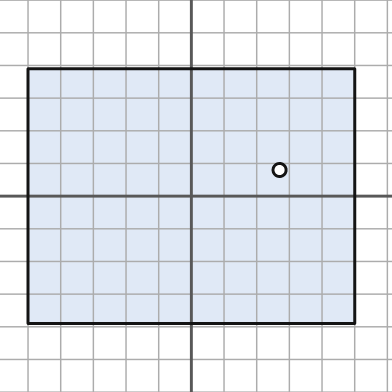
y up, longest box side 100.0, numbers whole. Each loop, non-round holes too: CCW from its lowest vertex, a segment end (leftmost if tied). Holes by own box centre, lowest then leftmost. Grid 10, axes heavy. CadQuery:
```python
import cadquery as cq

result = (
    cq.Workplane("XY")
    .moveTo(-50.0, -39.0)
    .lineTo(50.0, -39.0)
    .lineTo(50.0, 39.0)
    .lineTo(-50.0, 39.0)
    .close()
    .moveTo(27.0, 8.0)
    .circle(2.0)
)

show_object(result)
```